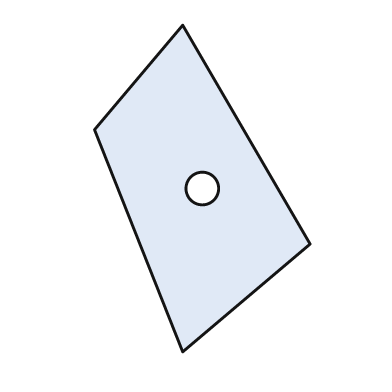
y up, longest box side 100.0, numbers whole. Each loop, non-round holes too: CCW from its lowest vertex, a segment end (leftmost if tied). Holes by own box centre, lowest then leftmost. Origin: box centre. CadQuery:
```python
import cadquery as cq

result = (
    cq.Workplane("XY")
    .moveTo(-6.0, -50.0)
    .lineTo(33.0, -17.0)
    .lineTo(-6.0, 50.0)
    .lineTo(-33.0, 18.0)
    .close()
    .moveTo(0.0, 0.0)
    .circle(5.0)
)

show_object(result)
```